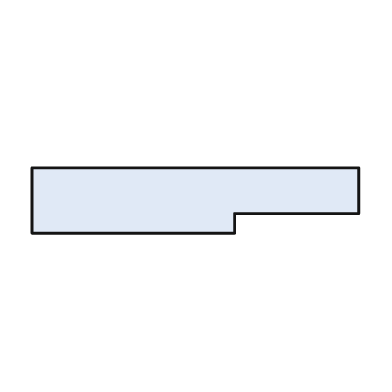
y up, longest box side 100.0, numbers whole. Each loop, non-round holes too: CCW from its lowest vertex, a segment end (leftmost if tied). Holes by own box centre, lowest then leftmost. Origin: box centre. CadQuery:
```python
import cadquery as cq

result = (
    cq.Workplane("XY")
    .moveTo(-50.0, -10.0)
    .lineTo(12.0, -10.0)
    .lineTo(12.0, -4.0)
    .lineTo(50.0, -4.0)
    .lineTo(50.0, 10.0)
    .lineTo(-50.0, 10.0)
    .close()
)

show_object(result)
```